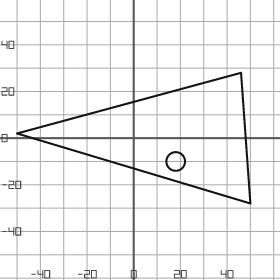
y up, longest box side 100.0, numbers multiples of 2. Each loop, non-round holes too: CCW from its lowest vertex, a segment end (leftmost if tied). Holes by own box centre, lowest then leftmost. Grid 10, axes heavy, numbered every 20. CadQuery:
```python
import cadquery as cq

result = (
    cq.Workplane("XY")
    .moveTo(50.0, -28.0)
    .lineTo(46.0, 28.0)
    .lineTo(-50.0, 2.0)
    .close()
    .moveTo(18.0, -10.0)
    .circle(4.0)
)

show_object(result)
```